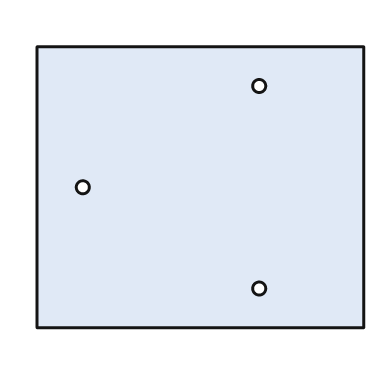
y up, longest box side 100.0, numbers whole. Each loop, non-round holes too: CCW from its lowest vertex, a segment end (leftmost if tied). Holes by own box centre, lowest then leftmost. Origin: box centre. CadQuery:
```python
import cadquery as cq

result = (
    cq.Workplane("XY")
    .moveTo(-50.0, -43.0)
    .lineTo(50.0, -43.0)
    .lineTo(50.0, 43.0)
    .lineTo(-50.0, 43.0)
    .close()
    .moveTo(18.0, -31.0)
    .circle(2.0)
    .moveTo(-36.0, 0.0)
    .circle(2.0)
    .moveTo(18.0, 31.0)
    .circle(2.0)
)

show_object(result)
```